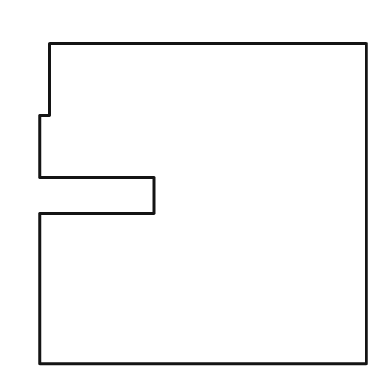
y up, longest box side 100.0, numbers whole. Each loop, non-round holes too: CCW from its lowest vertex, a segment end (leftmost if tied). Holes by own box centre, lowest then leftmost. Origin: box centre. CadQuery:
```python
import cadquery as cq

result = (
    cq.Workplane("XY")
    .moveTo(-50.0, -49.0)
    .lineTo(50.0, -49.0)
    .lineTo(50.0, 49.0)
    .lineTo(-47.0, 49.0)
    .lineTo(-47.0, 27.0)
    .lineTo(-50.0, 27.0)
    .lineTo(-50.0, 8.0)
    .lineTo(-15.0, 8.0)
    .lineTo(-15.0, -3.0)
    .lineTo(-50.0, -3.0)
    .close()
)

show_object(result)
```